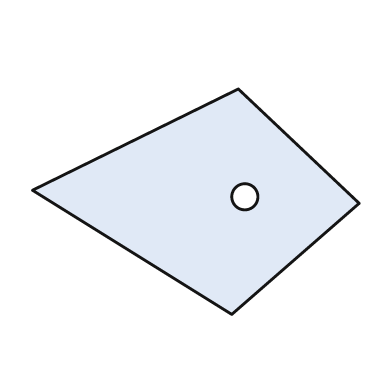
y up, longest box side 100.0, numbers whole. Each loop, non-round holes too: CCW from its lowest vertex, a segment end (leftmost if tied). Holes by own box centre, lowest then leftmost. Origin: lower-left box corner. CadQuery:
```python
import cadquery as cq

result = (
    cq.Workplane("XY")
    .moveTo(61.0, 0.0)
    .lineTo(100.0, 34.0)
    .lineTo(63.0, 69.0)
    .lineTo(0.0, 38.0)
    .close()
    .moveTo(65.0, 36.0)
    .circle(4.0)
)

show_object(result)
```